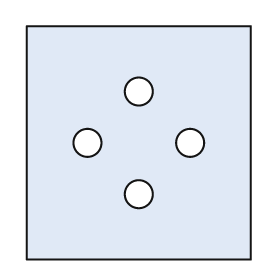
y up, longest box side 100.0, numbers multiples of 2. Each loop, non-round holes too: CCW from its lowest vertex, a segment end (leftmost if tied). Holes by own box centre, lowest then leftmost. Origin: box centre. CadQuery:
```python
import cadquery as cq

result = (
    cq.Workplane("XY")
    .moveTo(-48.0, -50.0)
    .lineTo(48.0, -50.0)
    .lineTo(48.0, 50.0)
    .lineTo(-48.0, 50.0)
    .close()
    .moveTo(0.0, -22.0)
    .circle(6.0)
    .moveTo(-22.0, 0.0)
    .circle(6.0)
    .moveTo(22.0, 0.0)
    .circle(6.0)
    .moveTo(0.0, 22.0)
    .circle(6.0)
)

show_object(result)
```